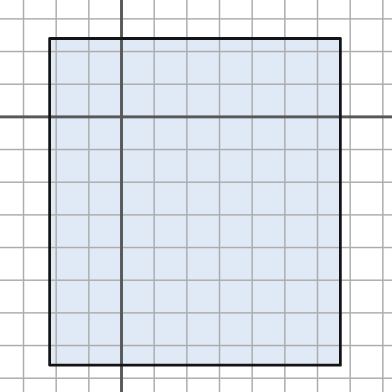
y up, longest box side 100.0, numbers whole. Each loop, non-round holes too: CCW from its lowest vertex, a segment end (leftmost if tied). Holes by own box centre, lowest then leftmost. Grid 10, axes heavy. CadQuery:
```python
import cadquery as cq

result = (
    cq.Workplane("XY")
    .moveTo(-22.0, -76.0)
    .lineTo(67.0, -76.0)
    .lineTo(67.0, 24.0)
    .lineTo(-22.0, 24.0)
    .close()
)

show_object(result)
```